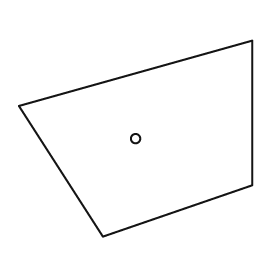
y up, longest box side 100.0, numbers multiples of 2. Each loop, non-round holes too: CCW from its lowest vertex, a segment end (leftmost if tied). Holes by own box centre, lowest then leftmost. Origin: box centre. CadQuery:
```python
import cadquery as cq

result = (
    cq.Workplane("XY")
    .moveTo(-14.0, -42.0)
    .lineTo(50.0, -20.0)
    .lineTo(50.0, 42.0)
    .lineTo(-50.0, 14.0)
    .close()
    .moveTo(0.0, 0.0)
    .circle(2.0)
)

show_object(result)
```